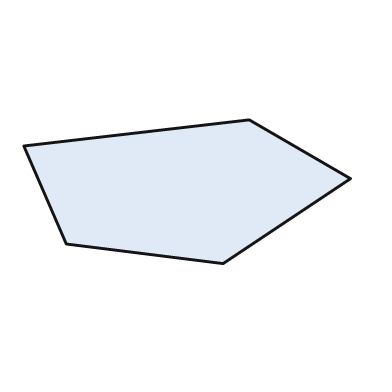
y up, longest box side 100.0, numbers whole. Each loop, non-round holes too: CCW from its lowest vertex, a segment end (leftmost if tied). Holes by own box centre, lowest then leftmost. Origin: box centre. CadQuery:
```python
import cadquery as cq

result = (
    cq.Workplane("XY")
    .moveTo(11.0, -22.0)
    .lineTo(50.0, 4.0)
    .lineTo(19.0, 22.0)
    .lineTo(-50.0, 14.0)
    .lineTo(-37.0, -16.0)
    .close()
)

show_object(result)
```